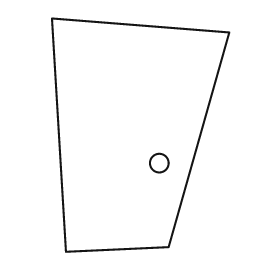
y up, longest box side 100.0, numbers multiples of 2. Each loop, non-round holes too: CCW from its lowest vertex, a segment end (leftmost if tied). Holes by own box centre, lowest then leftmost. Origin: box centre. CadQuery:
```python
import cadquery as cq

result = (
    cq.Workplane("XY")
    .moveTo(-32.0, -50.0)
    .lineTo(12.0, -48.0)
    .lineTo(38.0, 44.0)
    .lineTo(-38.0, 50.0)
    .close()
    .moveTo(8.0, -12.0)
    .circle(4.0)
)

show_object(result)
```